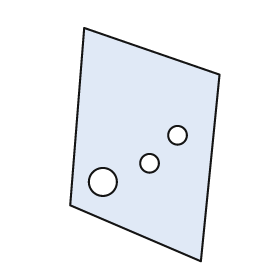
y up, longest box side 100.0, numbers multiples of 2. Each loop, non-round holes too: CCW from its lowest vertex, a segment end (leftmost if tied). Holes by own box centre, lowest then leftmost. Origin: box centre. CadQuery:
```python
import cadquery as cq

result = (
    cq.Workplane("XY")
    .moveTo(24.0, -50.0)
    .lineTo(32.0, 30.0)
    .lineTo(-26.0, 50.0)
    .lineTo(-32.0, -26.0)
    .close()
    .moveTo(-18.0, -16.0)
    .circle(6.0)
    .moveTo(2.0, -8.0)
    .circle(4.0)
    .moveTo(14.0, 4.0)
    .circle(4.0)
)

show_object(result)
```